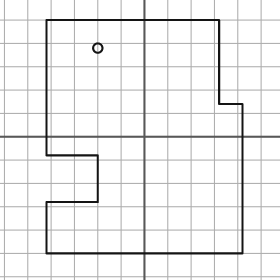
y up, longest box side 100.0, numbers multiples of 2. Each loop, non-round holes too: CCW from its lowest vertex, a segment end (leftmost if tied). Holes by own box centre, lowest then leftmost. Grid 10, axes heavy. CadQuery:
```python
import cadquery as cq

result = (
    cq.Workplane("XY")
    .moveTo(-42.0, -50.0)
    .lineTo(42.0, -50.0)
    .lineTo(42.0, 14.0)
    .lineTo(32.0, 14.0)
    .lineTo(32.0, 50.0)
    .lineTo(-42.0, 50.0)
    .lineTo(-42.0, -8.0)
    .lineTo(-20.0, -8.0)
    .lineTo(-20.0, -28.0)
    .lineTo(-42.0, -28.0)
    .close()
    .moveTo(-20.0, 38.0)
    .circle(2.0)
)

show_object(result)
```